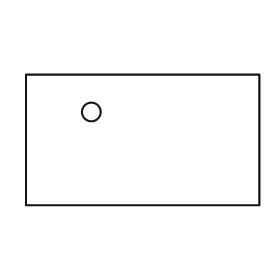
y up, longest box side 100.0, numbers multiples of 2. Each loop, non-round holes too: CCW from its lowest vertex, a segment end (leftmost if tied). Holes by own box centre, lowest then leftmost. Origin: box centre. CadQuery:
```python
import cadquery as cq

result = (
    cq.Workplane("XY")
    .moveTo(-50.0, -28.0)
    .lineTo(50.0, -28.0)
    .lineTo(50.0, 28.0)
    .lineTo(-50.0, 28.0)
    .close()
    .moveTo(-22.0, 12.0)
    .circle(4.0)
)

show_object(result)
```